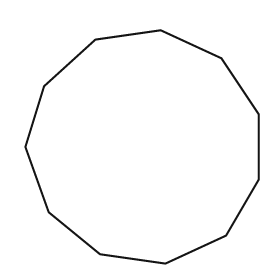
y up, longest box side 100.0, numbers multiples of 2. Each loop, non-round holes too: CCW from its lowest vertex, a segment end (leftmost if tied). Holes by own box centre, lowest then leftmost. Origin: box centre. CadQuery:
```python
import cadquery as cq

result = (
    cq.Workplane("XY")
    .moveTo(10.0, -50.0)
    .lineTo(36.0, -38.0)
    .lineTo(50.0, -14.0)
    .lineTo(50.0, 14.0)
    .lineTo(34.0, 38.0)
    .lineTo(8.0, 50.0)
    .lineTo(-20.0, 46.0)
    .lineTo(-42.0, 26.0)
    .lineTo(-50.0, 0.0)
    .lineTo(-40.0, -28.0)
    .lineTo(-18.0, -46.0)
    .close()
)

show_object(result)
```